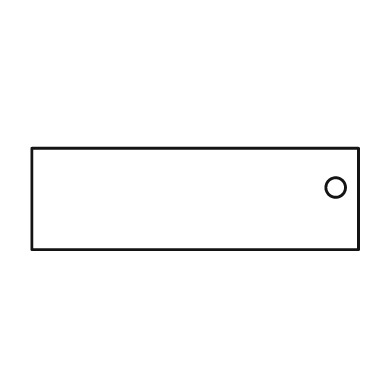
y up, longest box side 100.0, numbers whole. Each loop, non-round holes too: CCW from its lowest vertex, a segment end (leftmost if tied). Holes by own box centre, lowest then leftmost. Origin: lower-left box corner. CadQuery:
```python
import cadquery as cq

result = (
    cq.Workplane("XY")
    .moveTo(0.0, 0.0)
    .lineTo(100.0, 0.0)
    .lineTo(100.0, 31.0)
    .lineTo(0.0, 31.0)
    .close()
    .moveTo(93.0, 19.0)
    .circle(3.0)
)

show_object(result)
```